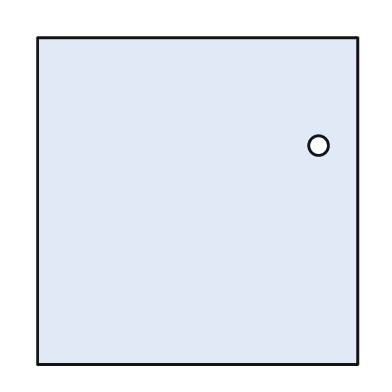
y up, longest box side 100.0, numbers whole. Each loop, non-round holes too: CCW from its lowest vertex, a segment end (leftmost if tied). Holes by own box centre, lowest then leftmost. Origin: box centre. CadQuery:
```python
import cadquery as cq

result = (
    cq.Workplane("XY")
    .moveTo(-49.0, -50.0)
    .lineTo(49.0, -50.0)
    .lineTo(49.0, 50.0)
    .lineTo(-49.0, 50.0)
    .close()
    .moveTo(37.0, 17.0)
    .circle(3.0)
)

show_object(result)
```